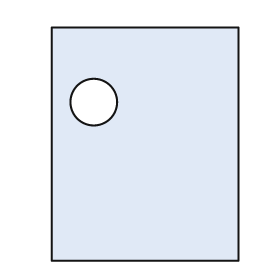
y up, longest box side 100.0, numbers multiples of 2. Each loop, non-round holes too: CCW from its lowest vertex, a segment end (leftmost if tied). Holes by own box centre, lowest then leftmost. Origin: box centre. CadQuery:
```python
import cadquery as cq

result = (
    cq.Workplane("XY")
    .moveTo(-40.0, -50.0)
    .lineTo(40.0, -50.0)
    .lineTo(40.0, 50.0)
    .lineTo(-40.0, 50.0)
    .close()
    .moveTo(-22.0, 18.0)
    .circle(10.0)
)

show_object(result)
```